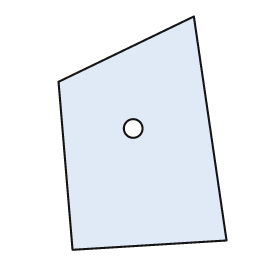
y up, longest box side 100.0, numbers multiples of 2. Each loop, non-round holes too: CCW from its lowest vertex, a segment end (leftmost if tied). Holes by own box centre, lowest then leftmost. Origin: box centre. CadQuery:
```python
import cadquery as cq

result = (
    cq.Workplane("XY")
    .moveTo(-30.0, -50.0)
    .lineTo(36.0, -46.0)
    .lineTo(22.0, 50.0)
    .lineTo(-36.0, 22.0)
    .close()
    .moveTo(-4.0, 2.0)
    .circle(4.0)
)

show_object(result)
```